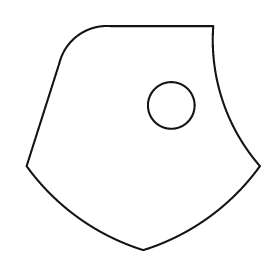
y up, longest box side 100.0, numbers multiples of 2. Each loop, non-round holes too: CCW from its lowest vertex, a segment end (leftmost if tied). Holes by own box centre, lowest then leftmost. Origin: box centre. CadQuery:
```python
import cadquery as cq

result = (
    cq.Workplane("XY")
    .moveTo(0.0, -48.0)
    .threePointArc((28.0, -34.0), (50.0, -12.0))
    .threePointArc((34.0, 16.0), (30.0, 48.0))
    .lineTo(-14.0, 48.0)
    .threePointArc((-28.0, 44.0), (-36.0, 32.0))
    .lineTo(-50.0, -12.0)
    .threePointArc((-28.0, -34.0), (0.0, -48.0))
    .close()
    .moveTo(12.0, 14.0)
    .circle(10.0)
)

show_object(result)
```